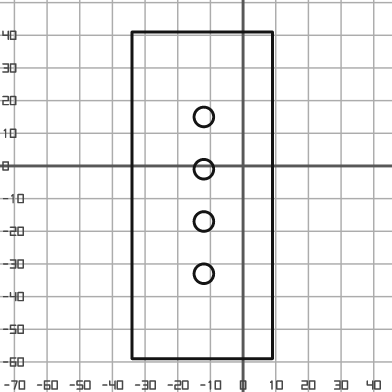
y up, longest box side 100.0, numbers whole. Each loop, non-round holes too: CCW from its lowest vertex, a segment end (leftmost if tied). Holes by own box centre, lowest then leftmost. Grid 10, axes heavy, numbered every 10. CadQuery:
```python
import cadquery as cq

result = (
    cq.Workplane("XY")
    .moveTo(-34.0, -59.0)
    .lineTo(9.0, -59.0)
    .lineTo(9.0, 41.0)
    .lineTo(-34.0, 41.0)
    .close()
    .moveTo(-12.0, -33.0)
    .circle(3.0)
    .moveTo(-12.0, -17.0)
    .circle(3.0)
    .moveTo(-12.0, -1.0)
    .circle(3.0)
    .moveTo(-12.0, 15.0)
    .circle(3.0)
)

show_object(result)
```